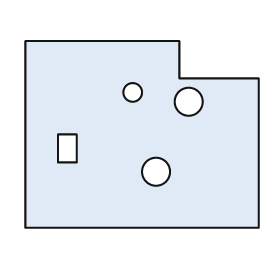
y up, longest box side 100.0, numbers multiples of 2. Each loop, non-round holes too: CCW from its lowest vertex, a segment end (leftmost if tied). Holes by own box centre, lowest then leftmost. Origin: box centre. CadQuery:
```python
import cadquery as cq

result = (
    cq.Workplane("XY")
    .moveTo(-50.0, -40.0)
    .lineTo(50.0, -40.0)
    .lineTo(50.0, 24.0)
    .lineTo(16.0, 24.0)
    .lineTo(16.0, 40.0)
    .lineTo(-50.0, 40.0)
    .close()
    .moveTo(6.0, -16.0)
    .circle(6.0)
    .moveTo(-36.0, -12.0)
    .lineTo(-28.0, -12.0)
    .lineTo(-28.0, 0.0)
    .lineTo(-36.0, 0.0)
    .close()
    .moveTo(20.0, 14.0)
    .circle(6.0)
    .moveTo(-4.0, 18.0)
    .circle(4.0)
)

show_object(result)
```